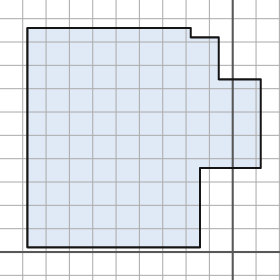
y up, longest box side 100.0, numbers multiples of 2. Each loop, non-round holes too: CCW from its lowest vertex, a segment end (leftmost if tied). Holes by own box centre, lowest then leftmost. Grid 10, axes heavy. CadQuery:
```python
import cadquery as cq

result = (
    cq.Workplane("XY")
    .moveTo(-88.0, 2.0)
    .lineTo(-14.0, 2.0)
    .lineTo(-14.0, 36.0)
    .lineTo(12.0, 36.0)
    .lineTo(12.0, 74.0)
    .lineTo(-6.0, 74.0)
    .lineTo(-6.0, 92.0)
    .lineTo(-18.0, 92.0)
    .lineTo(-18.0, 96.0)
    .lineTo(-88.0, 96.0)
    .close()
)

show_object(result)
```